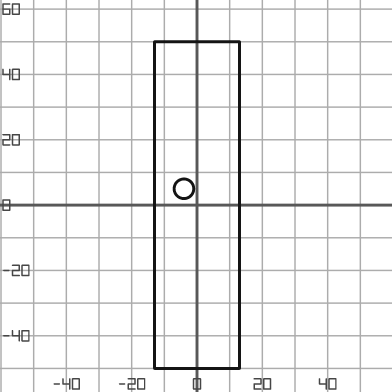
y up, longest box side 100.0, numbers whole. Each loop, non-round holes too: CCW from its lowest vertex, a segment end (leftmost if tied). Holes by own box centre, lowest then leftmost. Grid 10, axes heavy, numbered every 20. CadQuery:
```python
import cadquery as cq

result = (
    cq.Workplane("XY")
    .moveTo(-13.0, -50.0)
    .lineTo(13.0, -50.0)
    .lineTo(13.0, 50.0)
    .lineTo(-13.0, 50.0)
    .close()
    .moveTo(-4.0, 5.0)
    .circle(3.0)
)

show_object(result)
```